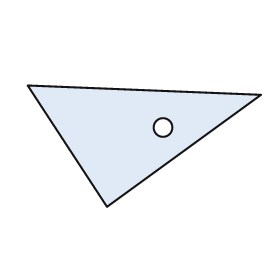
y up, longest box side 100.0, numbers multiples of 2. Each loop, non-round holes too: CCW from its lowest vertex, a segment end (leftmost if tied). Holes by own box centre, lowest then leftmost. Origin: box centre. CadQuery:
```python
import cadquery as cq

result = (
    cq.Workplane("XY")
    .moveTo(-16.0, -26.0)
    .lineTo(50.0, 22.0)
    .lineTo(-50.0, 26.0)
    .close()
    .moveTo(8.0, 8.0)
    .circle(4.0)
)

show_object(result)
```